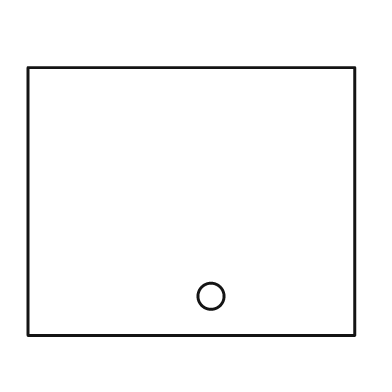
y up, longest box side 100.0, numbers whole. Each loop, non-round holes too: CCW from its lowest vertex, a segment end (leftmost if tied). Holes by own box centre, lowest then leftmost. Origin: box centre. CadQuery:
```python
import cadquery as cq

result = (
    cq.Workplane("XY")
    .moveTo(-50.0, -41.0)
    .lineTo(50.0, -41.0)
    .lineTo(50.0, 41.0)
    .lineTo(-50.0, 41.0)
    .close()
    .moveTo(6.0, -29.0)
    .circle(4.0)
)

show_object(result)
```